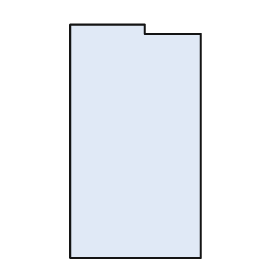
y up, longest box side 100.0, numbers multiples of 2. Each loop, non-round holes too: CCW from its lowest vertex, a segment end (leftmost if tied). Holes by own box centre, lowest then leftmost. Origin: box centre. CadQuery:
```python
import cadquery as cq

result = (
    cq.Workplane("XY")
    .moveTo(-28.0, -50.0)
    .lineTo(28.0, -50.0)
    .lineTo(28.0, 46.0)
    .lineTo(4.0, 46.0)
    .lineTo(4.0, 50.0)
    .lineTo(-28.0, 50.0)
    .close()
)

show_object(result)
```